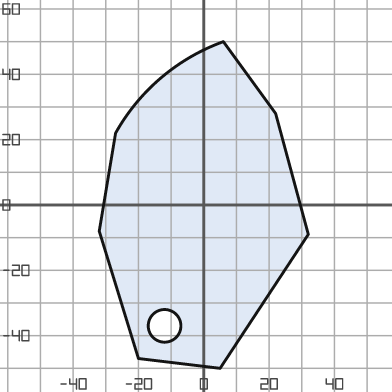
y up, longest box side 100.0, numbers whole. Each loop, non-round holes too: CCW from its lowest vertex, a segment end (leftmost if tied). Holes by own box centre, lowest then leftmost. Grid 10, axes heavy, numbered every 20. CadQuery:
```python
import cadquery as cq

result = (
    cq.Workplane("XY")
    .moveTo(5.0, -50.0)
    .lineTo(32.0, -9.0)
    .lineTo(22.0, 28.0)
    .lineTo(6.0, 50.0)
    .threePointArc((-13.0, 39.0), (-27.0, 22.0))
    .lineTo(-32.0, -8.0)
    .lineTo(-20.0, -47.0)
    .close()
    .moveTo(-12.0, -37.0)
    .circle(5.0)
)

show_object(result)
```